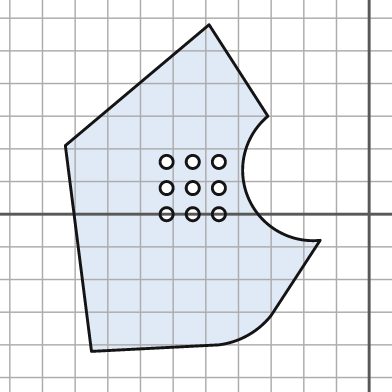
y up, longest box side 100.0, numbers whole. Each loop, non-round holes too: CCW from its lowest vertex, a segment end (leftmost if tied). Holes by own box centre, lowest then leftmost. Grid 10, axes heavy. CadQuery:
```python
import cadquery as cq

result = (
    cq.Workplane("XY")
    .moveTo(-85.0, -42.0)
    .lineTo(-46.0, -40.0)
    .threePointArc((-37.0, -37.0), (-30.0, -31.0))
    .lineTo(-15.0, -8.0)
    .threePointArc((-37.0, 5.0), (-31.0, 30.0))
    .lineTo(-49.0, 58.0)
    .lineTo(-93.0, 21.0)
    .close()
    .moveTo(-62.0, 0.0)
    .circle(2.0)
    .moveTo(-54.0, 0.0)
    .circle(2.0)
    .moveTo(-46.0, 0.0)
    .circle(2.0)
    .moveTo(-62.0, 8.0)
    .circle(2.0)
    .moveTo(-54.0, 8.0)
    .circle(2.0)
    .moveTo(-46.0, 8.0)
    .circle(2.0)
    .moveTo(-62.0, 16.0)
    .circle(2.0)
    .moveTo(-54.0, 16.0)
    .circle(2.0)
    .moveTo(-46.0, 16.0)
    .circle(2.0)
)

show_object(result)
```